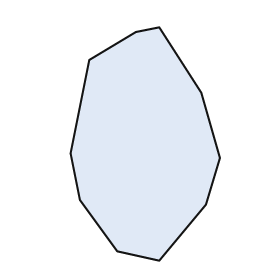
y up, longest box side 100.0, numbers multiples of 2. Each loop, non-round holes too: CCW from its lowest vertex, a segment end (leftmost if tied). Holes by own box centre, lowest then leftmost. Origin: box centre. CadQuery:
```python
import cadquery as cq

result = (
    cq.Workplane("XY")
    .moveTo(6.0, -50.0)
    .lineTo(26.0, -26.0)
    .lineTo(32.0, -6.0)
    .lineTo(24.0, 22.0)
    .lineTo(6.0, 50.0)
    .lineTo(-4.0, 48.0)
    .lineTo(-24.0, 36.0)
    .lineTo(-32.0, -4.0)
    .lineTo(-28.0, -24.0)
    .lineTo(-12.0, -46.0)
    .close()
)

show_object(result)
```